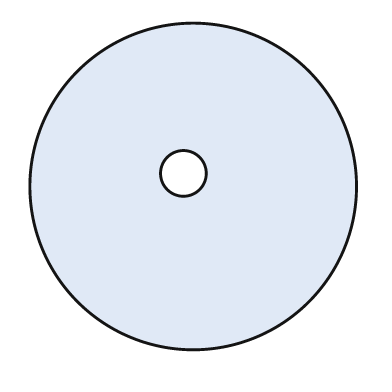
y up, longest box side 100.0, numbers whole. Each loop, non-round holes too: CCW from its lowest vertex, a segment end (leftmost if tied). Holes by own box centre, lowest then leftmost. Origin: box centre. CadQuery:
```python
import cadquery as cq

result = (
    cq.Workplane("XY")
    .moveTo(0.0, 0.0)
    .circle(50.0)
    .moveTo(-3.0, 4.0)
    .circle(7.0)
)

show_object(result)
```